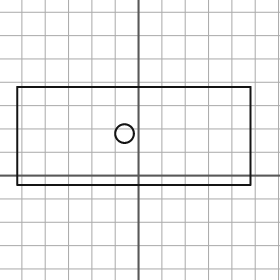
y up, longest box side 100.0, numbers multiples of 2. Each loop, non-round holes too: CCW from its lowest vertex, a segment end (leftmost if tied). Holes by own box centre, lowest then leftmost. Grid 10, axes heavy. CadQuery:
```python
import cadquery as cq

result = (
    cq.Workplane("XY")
    .moveTo(-52.0, -4.0)
    .lineTo(48.0, -4.0)
    .lineTo(48.0, 38.0)
    .lineTo(-52.0, 38.0)
    .close()
    .moveTo(-6.0, 18.0)
    .circle(4.0)
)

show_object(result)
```